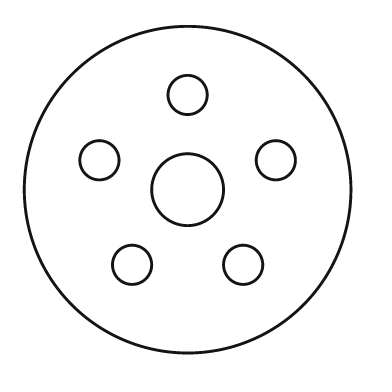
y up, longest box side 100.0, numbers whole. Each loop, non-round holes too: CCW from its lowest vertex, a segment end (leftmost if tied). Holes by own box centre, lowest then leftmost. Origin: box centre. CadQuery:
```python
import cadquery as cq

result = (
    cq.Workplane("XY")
    .moveTo(0.0, 0.0)
    .circle(50.0)
    .moveTo(-17.0, -23.0)
    .circle(6.0)
    .moveTo(17.0, -23.0)
    .circle(6.0)
    .moveTo(0.0, 0.0)
    .circle(11.0)
    .moveTo(-27.0, 9.0)
    .circle(6.0)
    .moveTo(27.0, 9.0)
    .circle(6.0)
    .moveTo(0.0, 29.0)
    .circle(6.0)
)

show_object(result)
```